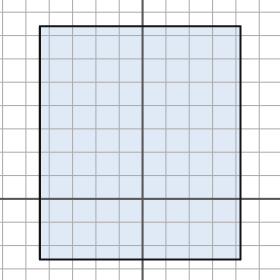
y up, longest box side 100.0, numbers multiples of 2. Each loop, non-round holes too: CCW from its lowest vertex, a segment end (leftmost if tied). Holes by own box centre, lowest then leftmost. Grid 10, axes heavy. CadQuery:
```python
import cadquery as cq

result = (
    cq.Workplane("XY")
    .moveTo(-44.0, -26.0)
    .lineTo(42.0, -26.0)
    .lineTo(42.0, 74.0)
    .lineTo(-44.0, 74.0)
    .close()
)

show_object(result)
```